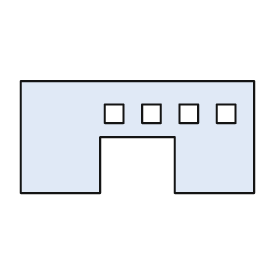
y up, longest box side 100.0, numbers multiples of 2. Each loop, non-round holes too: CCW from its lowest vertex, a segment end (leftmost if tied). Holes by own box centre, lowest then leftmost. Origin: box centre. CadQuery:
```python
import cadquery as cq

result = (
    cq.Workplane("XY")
    .moveTo(-50.0, -24.0)
    .lineTo(-16.0, -24.0)
    .lineTo(-16.0, 0.0)
    .lineTo(16.0, 0.0)
    .lineTo(16.0, -24.0)
    .lineTo(50.0, -24.0)
    .lineTo(50.0, 24.0)
    .lineTo(-50.0, 24.0)
    .close()
    .moveTo(-14.0, 6.0)
    .lineTo(-6.0, 6.0)
    .lineTo(-6.0, 14.0)
    .lineTo(-14.0, 14.0)
    .close()
    .moveTo(2.0, 6.0)
    .lineTo(10.0, 6.0)
    .lineTo(10.0, 14.0)
    .lineTo(2.0, 14.0)
    .close()
    .moveTo(18.0, 6.0)
    .lineTo(26.0, 6.0)
    .lineTo(26.0, 14.0)
    .lineTo(18.0, 14.0)
    .close()
    .moveTo(34.0, 6.0)
    .lineTo(42.0, 6.0)
    .lineTo(42.0, 14.0)
    .lineTo(34.0, 14.0)
    .close()
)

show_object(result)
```